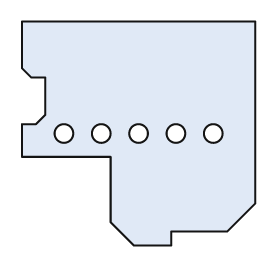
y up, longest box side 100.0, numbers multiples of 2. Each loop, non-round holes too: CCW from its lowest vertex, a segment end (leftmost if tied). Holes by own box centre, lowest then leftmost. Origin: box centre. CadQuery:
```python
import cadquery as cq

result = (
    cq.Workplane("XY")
    .moveTo(-2.0, -48.0)
    .lineTo(14.0, -48.0)
    .lineTo(14.0, -42.0)
    .lineTo(38.0, -42.0)
    .lineTo(50.0, -30.0)
    .lineTo(50.0, 48.0)
    .lineTo(-50.0, 48.0)
    .lineTo(-50.0, 28.0)
    .lineTo(-46.0, 24.0)
    .lineTo(-40.0, 24.0)
    .lineTo(-40.0, 8.0)
    .lineTo(-44.0, 4.0)
    .lineTo(-50.0, 4.0)
    .lineTo(-50.0, -10.0)
    .lineTo(-12.0, -10.0)
    .lineTo(-12.0, -38.0)
    .close()
    .moveTo(-32.0, 0.0)
    .circle(4.0)
    .moveTo(-16.0, 0.0)
    .circle(4.0)
    .moveTo(0.0, 0.0)
    .circle(4.0)
    .moveTo(16.0, 0.0)
    .circle(4.0)
    .moveTo(32.0, 0.0)
    .circle(4.0)
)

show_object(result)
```